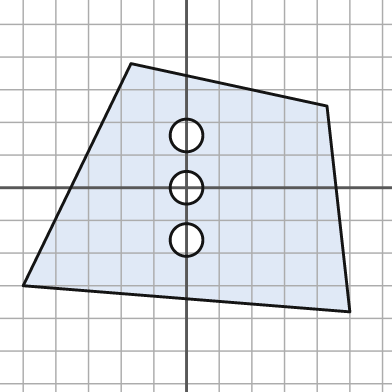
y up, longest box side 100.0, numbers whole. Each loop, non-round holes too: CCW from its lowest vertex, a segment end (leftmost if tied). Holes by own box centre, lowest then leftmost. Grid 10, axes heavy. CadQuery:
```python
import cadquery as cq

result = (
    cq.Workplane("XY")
    .moveTo(50.0, -38.0)
    .lineTo(43.0, 25.0)
    .lineTo(-17.0, 38.0)
    .lineTo(-50.0, -30.0)
    .close()
    .moveTo(0.0, -16.0)
    .circle(5.0)
    .moveTo(0.0, 0.0)
    .circle(5.0)
    .moveTo(0.0, 16.0)
    .circle(5.0)
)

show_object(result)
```